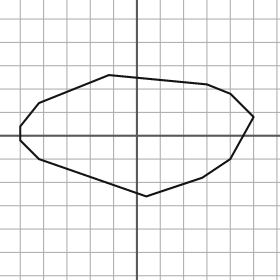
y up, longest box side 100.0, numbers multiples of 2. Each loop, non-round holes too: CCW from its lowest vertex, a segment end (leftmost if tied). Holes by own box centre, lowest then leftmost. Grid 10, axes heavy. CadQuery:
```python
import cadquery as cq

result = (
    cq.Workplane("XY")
    .moveTo(4.0, -26.0)
    .lineTo(28.0, -18.0)
    .lineTo(40.0, -10.0)
    .lineTo(50.0, 8.0)
    .lineTo(40.0, 18.0)
    .lineTo(30.0, 22.0)
    .lineTo(-12.0, 26.0)
    .lineTo(-42.0, 14.0)
    .lineTo(-50.0, 4.0)
    .lineTo(-50.0, -2.0)
    .lineTo(-42.0, -10.0)
    .close()
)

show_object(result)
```